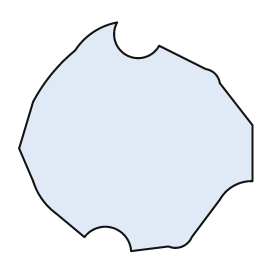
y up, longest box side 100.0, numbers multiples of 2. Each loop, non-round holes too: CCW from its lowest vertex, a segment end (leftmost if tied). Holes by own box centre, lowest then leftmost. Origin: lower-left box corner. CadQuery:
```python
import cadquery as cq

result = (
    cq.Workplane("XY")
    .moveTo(48.0, 0.0)
    .lineTo(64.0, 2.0)
    .threePointArc((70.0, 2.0), (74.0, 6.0))
    .lineTo(86.0, 22.0)
    .threePointArc((92.0, 28.0), (100.0, 30.0))
    .lineTo(100.0, 54.0)
    .lineTo(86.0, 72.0)
    .threePointArc((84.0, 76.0), (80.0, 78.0))
    .lineTo(60.0, 88.0)
    .threePointArc((46.0, 84.0), (42.0, 98.0))
    .threePointArc((32.0, 94.0), (24.0, 86.0))
    .threePointArc((14.0, 76.0), (6.0, 64.0))
    .lineTo(0.0, 44.0)
    .lineTo(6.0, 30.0)
    .threePointArc((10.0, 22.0), (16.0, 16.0))
    .lineTo(28.0, 6.0)
    .threePointArc((40.0, 10.0), (48.0, 0.0))
    .close()
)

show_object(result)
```